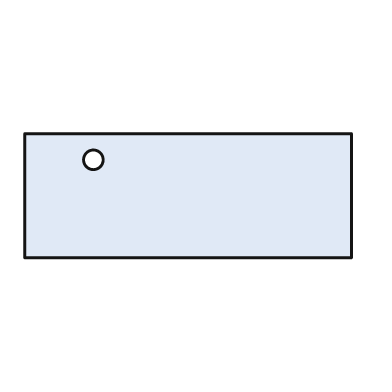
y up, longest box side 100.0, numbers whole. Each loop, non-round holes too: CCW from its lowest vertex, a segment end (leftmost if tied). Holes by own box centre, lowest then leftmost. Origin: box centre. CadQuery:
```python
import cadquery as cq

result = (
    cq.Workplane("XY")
    .moveTo(-50.0, -19.0)
    .lineTo(50.0, -19.0)
    .lineTo(50.0, 19.0)
    .lineTo(-50.0, 19.0)
    .close()
    .moveTo(-29.0, 11.0)
    .circle(3.0)
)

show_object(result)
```